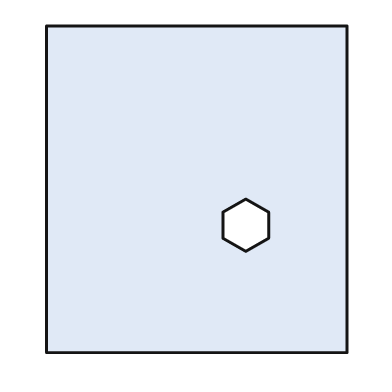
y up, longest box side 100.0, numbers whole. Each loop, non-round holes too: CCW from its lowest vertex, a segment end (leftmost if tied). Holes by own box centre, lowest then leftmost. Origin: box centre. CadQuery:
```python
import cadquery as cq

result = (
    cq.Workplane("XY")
    .moveTo(-46.0, -50.0)
    .lineTo(46.0, -50.0)
    .lineTo(46.0, 50.0)
    .lineTo(-46.0, 50.0)
    .close()
    .moveTo(15.0, -19.0)
    .lineTo(22.0, -15.0)
    .lineTo(22.0, -7.0)
    .lineTo(15.0, -3.0)
    .lineTo(8.0, -7.0)
    .lineTo(8.0, -15.0)
    .close()
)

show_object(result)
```